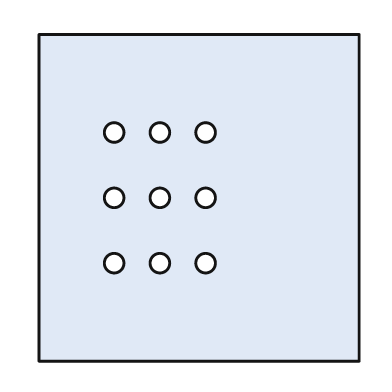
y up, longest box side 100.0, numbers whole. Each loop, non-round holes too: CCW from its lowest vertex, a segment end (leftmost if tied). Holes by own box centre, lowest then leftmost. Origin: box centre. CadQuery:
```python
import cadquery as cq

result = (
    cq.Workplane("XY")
    .moveTo(-49.0, -50.0)
    .lineTo(49.0, -50.0)
    .lineTo(49.0, 50.0)
    .lineTo(-49.0, 50.0)
    .close()
    .moveTo(-26.0, -20.0)
    .circle(3.0)
    .moveTo(-12.0, -20.0)
    .circle(3.0)
    .moveTo(2.0, -20.0)
    .circle(3.0)
    .moveTo(-26.0, 0.0)
    .circle(3.0)
    .moveTo(-12.0, 0.0)
    .circle(3.0)
    .moveTo(2.0, 0.0)
    .circle(3.0)
    .moveTo(-26.0, 20.0)
    .circle(3.0)
    .moveTo(-12.0, 20.0)
    .circle(3.0)
    .moveTo(2.0, 20.0)
    .circle(3.0)
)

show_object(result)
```